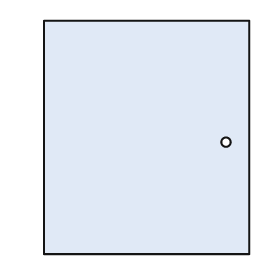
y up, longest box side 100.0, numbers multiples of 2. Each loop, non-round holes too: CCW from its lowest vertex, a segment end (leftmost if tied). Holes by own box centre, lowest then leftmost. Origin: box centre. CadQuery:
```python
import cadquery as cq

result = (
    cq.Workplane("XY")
    .moveTo(-44.0, -50.0)
    .lineTo(44.0, -50.0)
    .lineTo(44.0, 50.0)
    .lineTo(-44.0, 50.0)
    .close()
    .moveTo(34.0, -2.0)
    .circle(2.0)
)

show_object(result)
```